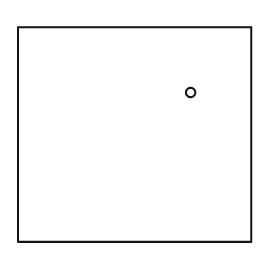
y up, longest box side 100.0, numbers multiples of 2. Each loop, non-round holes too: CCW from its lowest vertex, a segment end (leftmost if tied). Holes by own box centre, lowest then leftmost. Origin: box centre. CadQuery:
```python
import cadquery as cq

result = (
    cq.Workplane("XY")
    .moveTo(-50.0, -46.0)
    .lineTo(50.0, -46.0)
    .lineTo(50.0, 46.0)
    .lineTo(-50.0, 46.0)
    .close()
    .moveTo(24.0, 18.0)
    .circle(2.0)
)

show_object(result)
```